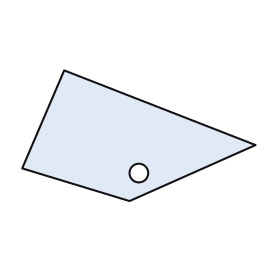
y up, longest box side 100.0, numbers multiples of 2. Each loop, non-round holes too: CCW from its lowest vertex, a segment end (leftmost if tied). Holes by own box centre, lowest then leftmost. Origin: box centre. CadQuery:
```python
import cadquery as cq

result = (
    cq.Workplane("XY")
    .moveTo(-4.0, -28.0)
    .lineTo(50.0, -4.0)
    .lineTo(-32.0, 28.0)
    .lineTo(-50.0, -14.0)
    .close()
    .moveTo(0.0, -16.0)
    .circle(4.0)
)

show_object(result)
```